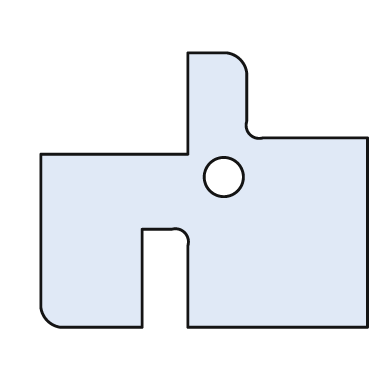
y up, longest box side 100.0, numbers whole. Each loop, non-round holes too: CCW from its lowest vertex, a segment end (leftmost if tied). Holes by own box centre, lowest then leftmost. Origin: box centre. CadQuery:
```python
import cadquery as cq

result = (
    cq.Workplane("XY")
    .moveTo(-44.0, -42.0)
    .lineTo(-19.0, -42.0)
    .lineTo(-19.0, -12.0)
    .lineTo(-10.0, -12.0)
    .threePointArc((-6.0, -13.0), (-5.0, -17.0))
    .lineTo(-5.0, -42.0)
    .lineTo(50.0, -42.0)
    .lineTo(50.0, 16.0)
    .lineTo(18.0, 16.0)
    .threePointArc((14.0, 17.0), (13.0, 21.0))
    .lineTo(13.0, 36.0)
    .threePointArc((11.0, 40.0), (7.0, 42.0))
    .lineTo(-5.0, 42.0)
    .lineTo(-5.0, 11.0)
    .lineTo(-50.0, 11.0)
    .lineTo(-50.0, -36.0)
    .threePointArc((-48.0, -40.0), (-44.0, -42.0))
    .close()
    .moveTo(6.0, 4.0)
    .circle(6.0)
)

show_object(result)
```